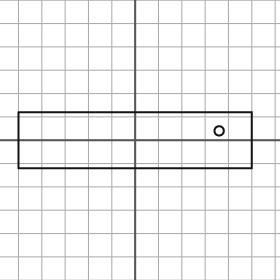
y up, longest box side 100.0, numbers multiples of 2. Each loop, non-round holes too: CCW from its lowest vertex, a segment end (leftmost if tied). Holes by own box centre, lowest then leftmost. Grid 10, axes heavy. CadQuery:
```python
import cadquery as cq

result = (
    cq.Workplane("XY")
    .moveTo(-50.0, -12.0)
    .lineTo(50.0, -12.0)
    .lineTo(50.0, 12.0)
    .lineTo(-50.0, 12.0)
    .close()
    .moveTo(36.0, 4.0)
    .circle(2.0)
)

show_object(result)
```